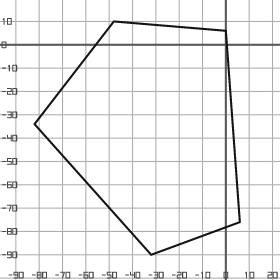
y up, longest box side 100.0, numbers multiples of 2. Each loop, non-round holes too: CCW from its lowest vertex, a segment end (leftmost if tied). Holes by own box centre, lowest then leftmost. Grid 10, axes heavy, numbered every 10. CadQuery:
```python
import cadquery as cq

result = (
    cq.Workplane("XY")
    .moveTo(-32.0, -90.0)
    .lineTo(6.0, -76.0)
    .lineTo(0.0, 6.0)
    .lineTo(-48.0, 10.0)
    .lineTo(-82.0, -34.0)
    .close()
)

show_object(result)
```